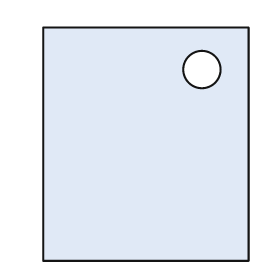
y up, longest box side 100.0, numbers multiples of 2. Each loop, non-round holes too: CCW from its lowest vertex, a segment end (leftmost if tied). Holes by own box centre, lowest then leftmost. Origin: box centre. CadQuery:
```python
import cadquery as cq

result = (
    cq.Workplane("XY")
    .moveTo(-44.0, -50.0)
    .lineTo(44.0, -50.0)
    .lineTo(44.0, 50.0)
    .lineTo(-44.0, 50.0)
    .close()
    .moveTo(24.0, 32.0)
    .circle(8.0)
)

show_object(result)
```